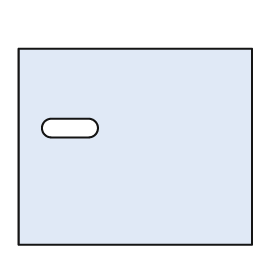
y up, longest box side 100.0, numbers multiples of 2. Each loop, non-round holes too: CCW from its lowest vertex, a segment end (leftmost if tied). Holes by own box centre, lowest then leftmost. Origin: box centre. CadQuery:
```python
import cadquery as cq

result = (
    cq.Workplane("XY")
    .moveTo(-50.0, -42.0)
    .lineTo(50.0, -42.0)
    .lineTo(50.0, 42.0)
    .lineTo(-50.0, 42.0)
    .close()
    .moveTo(-36.0, 4.0)
    .lineTo(-20.0, 4.0)
    .threePointArc((-16.0, 8.0), (-20.0, 12.0))
    .lineTo(-36.0, 12.0)
    .threePointArc((-40.0, 8.0), (-36.0, 4.0))
    .close()
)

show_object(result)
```